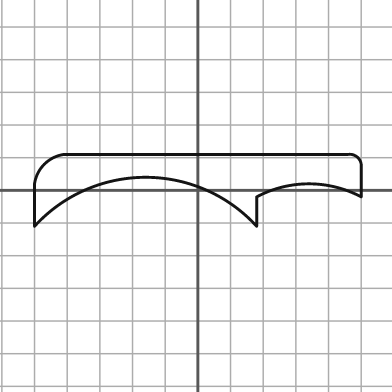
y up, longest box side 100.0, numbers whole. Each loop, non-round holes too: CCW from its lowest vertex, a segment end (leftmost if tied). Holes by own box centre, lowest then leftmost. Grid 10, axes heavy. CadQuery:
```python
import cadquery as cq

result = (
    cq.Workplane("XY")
    .moveTo(-50.0, -11.0)
    .threePointArc((-16.0, 4.0), (18.0, -11.0))
    .lineTo(18.0, -2.0)
    .threePointArc((34.0, 2.0), (50.0, -2.0))
    .lineTo(50.0, 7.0)
    .threePointArc((49.0, 10.0), (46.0, 11.0))
    .lineTo(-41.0, 11.0)
    .threePointArc((-47.0, 8.0), (-50.0, 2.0))
    .close()
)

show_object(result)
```